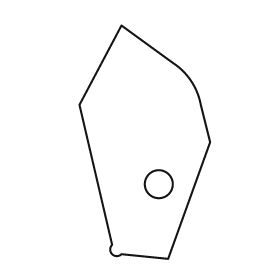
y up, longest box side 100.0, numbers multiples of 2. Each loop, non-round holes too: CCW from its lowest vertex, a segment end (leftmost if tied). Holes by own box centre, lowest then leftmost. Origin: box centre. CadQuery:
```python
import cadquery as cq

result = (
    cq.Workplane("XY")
    .moveTo(10.0, -50.0)
    .lineTo(28.0, 0.0)
    .lineTo(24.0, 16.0)
    .threePointArc((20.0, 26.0), (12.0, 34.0))
    .lineTo(-10.0, 50.0)
    .lineTo(-28.0, 16.0)
    .lineTo(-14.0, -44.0)
    .threePointArc((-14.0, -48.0), (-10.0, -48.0))
    .close()
    .moveTo(6.0, -18.0)
    .circle(6.0)
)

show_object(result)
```